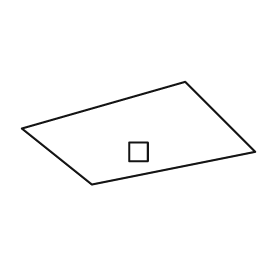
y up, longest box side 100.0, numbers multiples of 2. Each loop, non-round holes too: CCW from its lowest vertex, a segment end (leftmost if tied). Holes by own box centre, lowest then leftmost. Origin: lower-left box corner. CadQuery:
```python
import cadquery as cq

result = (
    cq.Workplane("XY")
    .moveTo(30.0, 0.0)
    .lineTo(100.0, 14.0)
    .lineTo(70.0, 44.0)
    .lineTo(0.0, 24.0)
    .close()
    .moveTo(46.0, 10.0)
    .lineTo(54.0, 10.0)
    .lineTo(54.0, 18.0)
    .lineTo(46.0, 18.0)
    .close()
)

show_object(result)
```